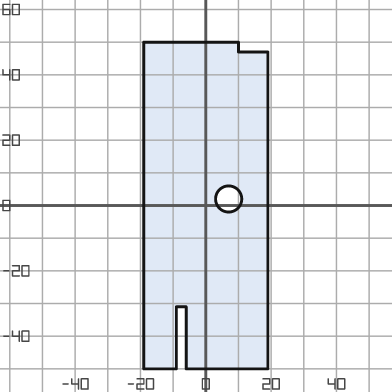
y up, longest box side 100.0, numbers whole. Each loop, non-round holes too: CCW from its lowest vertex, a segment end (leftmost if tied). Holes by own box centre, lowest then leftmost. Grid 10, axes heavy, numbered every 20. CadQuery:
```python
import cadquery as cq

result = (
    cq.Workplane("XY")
    .moveTo(-19.0, -50.0)
    .lineTo(-9.0, -50.0)
    .lineTo(-9.0, -31.0)
    .lineTo(-6.0, -31.0)
    .lineTo(-6.0, -50.0)
    .lineTo(19.0, -50.0)
    .lineTo(19.0, 47.0)
    .lineTo(10.0, 47.0)
    .lineTo(10.0, 50.0)
    .lineTo(-19.0, 50.0)
    .close()
    .moveTo(7.0, 2.0)
    .circle(4.0)
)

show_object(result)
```